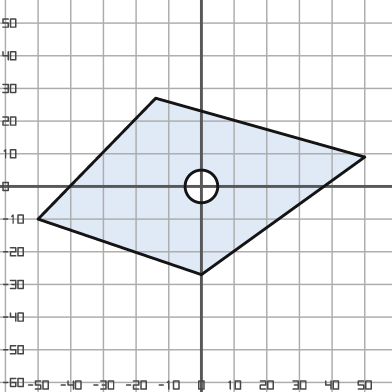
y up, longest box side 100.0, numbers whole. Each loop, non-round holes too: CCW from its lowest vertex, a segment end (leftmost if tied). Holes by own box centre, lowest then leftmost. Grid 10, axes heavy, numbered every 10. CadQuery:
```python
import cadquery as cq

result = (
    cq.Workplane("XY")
    .moveTo(0.0, -27.0)
    .lineTo(50.0, 9.0)
    .lineTo(-14.0, 27.0)
    .lineTo(-50.0, -10.0)
    .close()
    .moveTo(0.0, 0.0)
    .circle(5.0)
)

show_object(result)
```